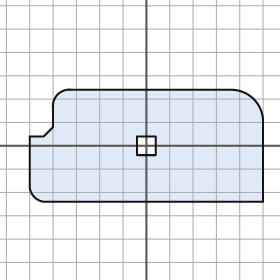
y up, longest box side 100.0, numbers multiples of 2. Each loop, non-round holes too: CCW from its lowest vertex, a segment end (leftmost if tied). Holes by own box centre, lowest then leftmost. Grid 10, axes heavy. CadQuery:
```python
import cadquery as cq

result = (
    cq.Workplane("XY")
    .moveTo(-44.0, -24.0)
    .lineTo(50.0, -24.0)
    .lineTo(50.0, 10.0)
    .threePointArc((46.0, 20.0), (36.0, 24.0))
    .lineTo(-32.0, 24.0)
    .threePointArc((-38.0, 22.0), (-40.0, 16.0))
    .lineTo(-40.0, 8.0)
    .lineTo(-44.0, 4.0)
    .lineTo(-50.0, 4.0)
    .lineTo(-50.0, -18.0)
    .threePointArc((-48.0, -22.0), (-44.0, -24.0))
    .close()
    .moveTo(-4.0, -4.0)
    .lineTo(4.0, -4.0)
    .lineTo(4.0, 4.0)
    .lineTo(-4.0, 4.0)
    .close()
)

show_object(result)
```